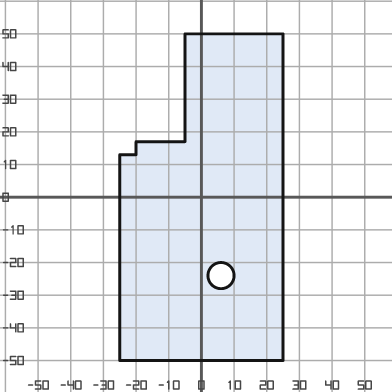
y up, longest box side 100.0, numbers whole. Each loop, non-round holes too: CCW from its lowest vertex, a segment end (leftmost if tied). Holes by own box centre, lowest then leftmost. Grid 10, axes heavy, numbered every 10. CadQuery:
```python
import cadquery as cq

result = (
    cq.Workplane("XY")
    .moveTo(-25.0, -50.0)
    .lineTo(25.0, -50.0)
    .lineTo(25.0, 50.0)
    .lineTo(-5.0, 50.0)
    .lineTo(-5.0, 17.0)
    .lineTo(-20.0, 17.0)
    .lineTo(-20.0, 13.0)
    .lineTo(-25.0, 13.0)
    .close()
    .moveTo(6.0, -24.0)
    .circle(4.0)
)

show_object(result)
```